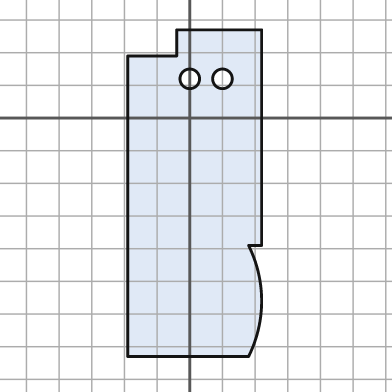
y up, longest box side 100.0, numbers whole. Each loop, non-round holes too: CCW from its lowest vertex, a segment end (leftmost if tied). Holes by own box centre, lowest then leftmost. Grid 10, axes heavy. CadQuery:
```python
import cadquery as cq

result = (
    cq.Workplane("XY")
    .moveTo(-19.0, -73.0)
    .lineTo(18.0, -73.0)
    .threePointArc((22.0, -56.0), (18.0, -39.0))
    .lineTo(22.0, -39.0)
    .lineTo(22.0, 27.0)
    .lineTo(-4.0, 27.0)
    .lineTo(-4.0, 19.0)
    .lineTo(-19.0, 19.0)
    .close()
    .moveTo(0.0, 12.0)
    .circle(3.0)
    .moveTo(10.0, 12.0)
    .circle(3.0)
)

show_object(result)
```